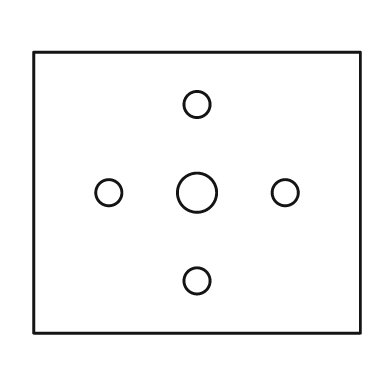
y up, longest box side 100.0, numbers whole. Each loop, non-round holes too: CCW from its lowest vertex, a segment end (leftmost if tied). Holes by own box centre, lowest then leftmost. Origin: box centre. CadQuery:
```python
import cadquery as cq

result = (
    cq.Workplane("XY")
    .moveTo(-50.0, -43.0)
    .lineTo(50.0, -43.0)
    .lineTo(50.0, 43.0)
    .lineTo(-50.0, 43.0)
    .close()
    .moveTo(0.0, -27.0)
    .circle(4.0)
    .moveTo(-27.0, 0.0)
    .circle(4.0)
    .moveTo(0.0, 0.0)
    .circle(6.0)
    .moveTo(27.0, 0.0)
    .circle(4.0)
    .moveTo(0.0, 27.0)
    .circle(4.0)
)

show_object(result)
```